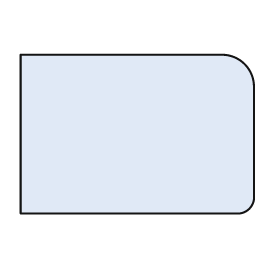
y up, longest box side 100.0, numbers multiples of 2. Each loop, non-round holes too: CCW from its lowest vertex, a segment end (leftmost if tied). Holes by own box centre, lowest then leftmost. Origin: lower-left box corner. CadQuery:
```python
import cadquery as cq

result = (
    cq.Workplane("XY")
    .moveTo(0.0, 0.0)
    .lineTo(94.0, 0.0)
    .threePointArc((98.0, 2.0), (100.0, 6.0))
    .lineTo(100.0, 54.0)
    .threePointArc((96.0, 64.0), (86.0, 68.0))
    .lineTo(0.0, 68.0)
    .close()
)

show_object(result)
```